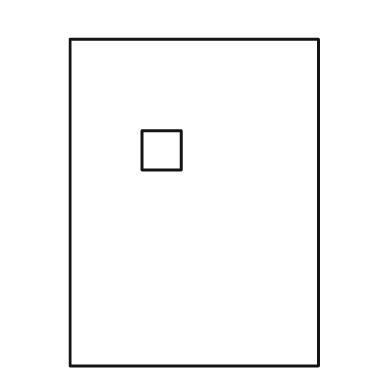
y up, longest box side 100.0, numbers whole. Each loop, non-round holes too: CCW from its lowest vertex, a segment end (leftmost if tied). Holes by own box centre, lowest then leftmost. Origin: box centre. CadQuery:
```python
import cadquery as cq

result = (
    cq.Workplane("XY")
    .moveTo(-38.0, -50.0)
    .lineTo(38.0, -50.0)
    .lineTo(38.0, 50.0)
    .lineTo(-38.0, 50.0)
    .close()
    .moveTo(-16.0, 10.0)
    .lineTo(-4.0, 10.0)
    .lineTo(-4.0, 22.0)
    .lineTo(-16.0, 22.0)
    .close()
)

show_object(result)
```